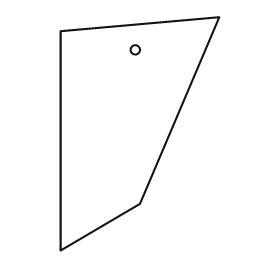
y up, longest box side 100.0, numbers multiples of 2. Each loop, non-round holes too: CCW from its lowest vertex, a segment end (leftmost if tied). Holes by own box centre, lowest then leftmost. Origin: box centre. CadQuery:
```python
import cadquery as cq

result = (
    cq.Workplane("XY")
    .moveTo(-34.0, -50.0)
    .lineTo(0.0, -30.0)
    .lineTo(34.0, 50.0)
    .lineTo(-34.0, 44.0)
    .close()
    .moveTo(-2.0, 36.0)
    .circle(2.0)
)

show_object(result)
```